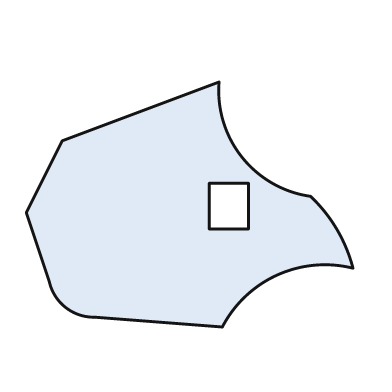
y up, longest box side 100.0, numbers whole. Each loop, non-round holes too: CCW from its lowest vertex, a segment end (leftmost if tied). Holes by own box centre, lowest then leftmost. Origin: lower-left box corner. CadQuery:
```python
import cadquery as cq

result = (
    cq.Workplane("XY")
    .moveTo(60.0, 0.0)
    .threePointArc((77.0, 16.0), (100.0, 18.0))
    .threePointArc((95.0, 30.0), (87.0, 40.0))
    .threePointArc((66.0, 52.0), (59.0, 75.0))
    .lineTo(11.0, 57.0)
    .lineTo(0.0, 35.0)
    .lineTo(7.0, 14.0)
    .threePointArc((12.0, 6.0), (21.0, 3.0))
    .close()
    .moveTo(56.0, 30.0)
    .lineTo(68.0, 30.0)
    .lineTo(68.0, 44.0)
    .lineTo(56.0, 44.0)
    .close()
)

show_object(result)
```